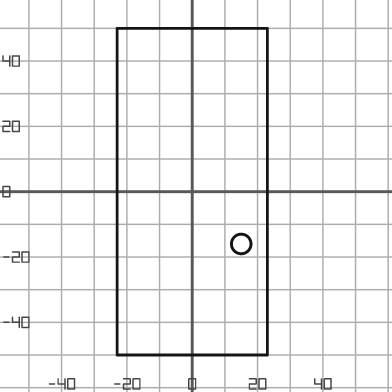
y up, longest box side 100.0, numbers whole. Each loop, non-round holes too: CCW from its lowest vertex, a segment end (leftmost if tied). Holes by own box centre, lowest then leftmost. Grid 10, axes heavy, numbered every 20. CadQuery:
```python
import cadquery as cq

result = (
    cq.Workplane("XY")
    .moveTo(-23.0, -50.0)
    .lineTo(23.0, -50.0)
    .lineTo(23.0, 50.0)
    .lineTo(-23.0, 50.0)
    .close()
    .moveTo(15.0, -16.0)
    .circle(3.0)
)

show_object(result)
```